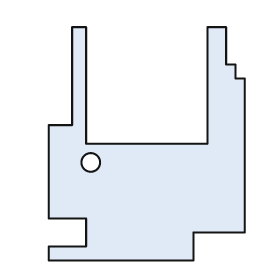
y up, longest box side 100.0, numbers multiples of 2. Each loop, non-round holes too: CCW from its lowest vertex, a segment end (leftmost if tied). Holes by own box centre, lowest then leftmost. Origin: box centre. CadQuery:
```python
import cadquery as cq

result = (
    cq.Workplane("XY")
    .moveTo(-42.0, -50.0)
    .lineTo(20.0, -50.0)
    .lineTo(20.0, -38.0)
    .lineTo(42.0, -38.0)
    .lineTo(42.0, 28.0)
    .lineTo(38.0, 28.0)
    .lineTo(38.0, 34.0)
    .lineTo(34.0, 34.0)
    .lineTo(34.0, 50.0)
    .lineTo(26.0, 50.0)
    .lineTo(26.0, 0.0)
    .lineTo(-26.0, 0.0)
    .lineTo(-26.0, 50.0)
    .lineTo(-32.0, 50.0)
    .lineTo(-32.0, 8.0)
    .lineTo(-42.0, 8.0)
    .lineTo(-42.0, -32.0)
    .lineTo(-26.0, -32.0)
    .lineTo(-26.0, -44.0)
    .lineTo(-42.0, -44.0)
    .close()
    .moveTo(-24.0, -8.0)
    .circle(4.0)
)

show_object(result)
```